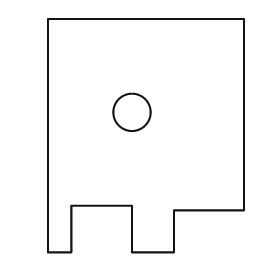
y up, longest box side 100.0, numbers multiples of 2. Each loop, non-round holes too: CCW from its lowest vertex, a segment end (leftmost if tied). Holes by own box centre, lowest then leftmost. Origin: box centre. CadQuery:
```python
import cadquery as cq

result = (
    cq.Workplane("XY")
    .moveTo(-42.0, -50.0)
    .lineTo(-32.0, -50.0)
    .lineTo(-32.0, -30.0)
    .lineTo(-6.0, -30.0)
    .lineTo(-6.0, -50.0)
    .lineTo(12.0, -50.0)
    .lineTo(12.0, -32.0)
    .lineTo(42.0, -32.0)
    .lineTo(42.0, 50.0)
    .lineTo(-42.0, 50.0)
    .close()
    .moveTo(-6.0, 10.0)
    .circle(8.0)
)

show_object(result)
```